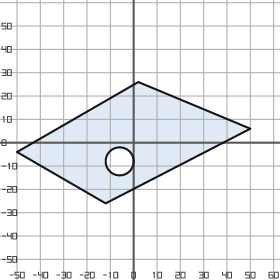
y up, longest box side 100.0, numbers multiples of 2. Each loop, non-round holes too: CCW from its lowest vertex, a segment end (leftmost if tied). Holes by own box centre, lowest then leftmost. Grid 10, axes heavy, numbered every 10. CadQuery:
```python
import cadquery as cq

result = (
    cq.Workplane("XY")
    .moveTo(-12.0, -26.0)
    .lineTo(50.0, 6.0)
    .lineTo(2.0, 26.0)
    .lineTo(-50.0, -4.0)
    .close()
    .moveTo(-6.0, -8.0)
    .circle(6.0)
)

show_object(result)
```